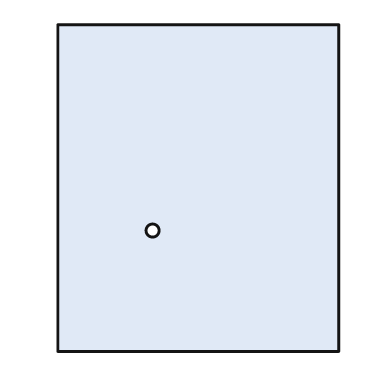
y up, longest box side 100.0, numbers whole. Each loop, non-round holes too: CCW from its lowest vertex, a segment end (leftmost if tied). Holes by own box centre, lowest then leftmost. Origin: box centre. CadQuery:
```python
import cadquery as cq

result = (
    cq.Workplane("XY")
    .moveTo(-43.0, -50.0)
    .lineTo(43.0, -50.0)
    .lineTo(43.0, 50.0)
    .lineTo(-43.0, 50.0)
    .close()
    .moveTo(-14.0, -13.0)
    .circle(2.0)
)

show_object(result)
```